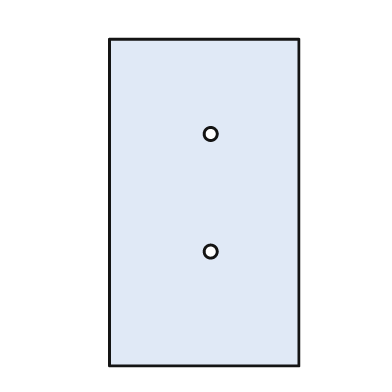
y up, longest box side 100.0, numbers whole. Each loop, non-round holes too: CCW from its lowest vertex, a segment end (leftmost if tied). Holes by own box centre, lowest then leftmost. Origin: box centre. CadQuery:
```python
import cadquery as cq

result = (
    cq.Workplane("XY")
    .moveTo(-29.0, -50.0)
    .lineTo(29.0, -50.0)
    .lineTo(29.0, 50.0)
    .lineTo(-29.0, 50.0)
    .close()
    .moveTo(2.0, -15.0)
    .circle(2.0)
    .moveTo(2.0, 21.0)
    .circle(2.0)
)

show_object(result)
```